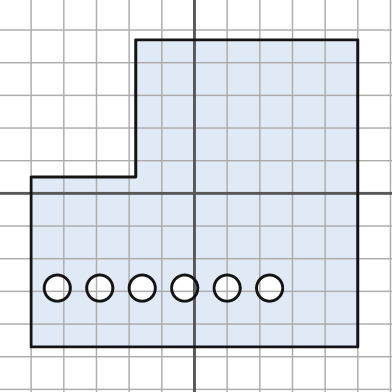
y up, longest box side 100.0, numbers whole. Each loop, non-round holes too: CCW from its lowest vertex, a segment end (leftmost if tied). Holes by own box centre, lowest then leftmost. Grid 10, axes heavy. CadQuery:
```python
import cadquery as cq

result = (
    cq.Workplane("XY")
    .moveTo(-50.0, -47.0)
    .lineTo(50.0, -47.0)
    .lineTo(50.0, 47.0)
    .lineTo(-18.0, 47.0)
    .lineTo(-18.0, 5.0)
    .lineTo(-50.0, 5.0)
    .close()
    .moveTo(-42.0, -29.0)
    .circle(4.0)
    .moveTo(-29.0, -29.0)
    .circle(4.0)
    .moveTo(-16.0, -29.0)
    .circle(4.0)
    .moveTo(-3.0, -29.0)
    .circle(4.0)
    .moveTo(10.0, -29.0)
    .circle(4.0)
    .moveTo(23.0, -29.0)
    .circle(4.0)
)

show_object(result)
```